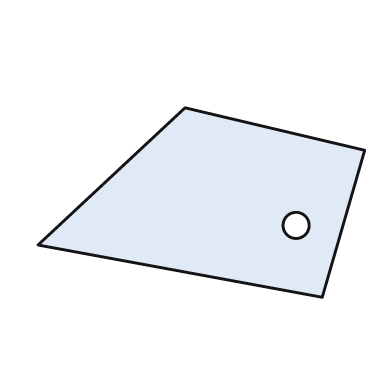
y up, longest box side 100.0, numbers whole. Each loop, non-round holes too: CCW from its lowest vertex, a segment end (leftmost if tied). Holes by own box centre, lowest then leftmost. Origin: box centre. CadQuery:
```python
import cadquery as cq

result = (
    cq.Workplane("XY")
    .moveTo(37.0, -29.0)
    .lineTo(50.0, 16.0)
    .lineTo(-5.0, 29.0)
    .lineTo(-50.0, -13.0)
    .close()
    .moveTo(29.0, -7.0)
    .circle(4.0)
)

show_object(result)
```